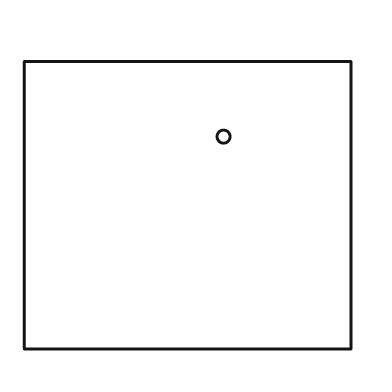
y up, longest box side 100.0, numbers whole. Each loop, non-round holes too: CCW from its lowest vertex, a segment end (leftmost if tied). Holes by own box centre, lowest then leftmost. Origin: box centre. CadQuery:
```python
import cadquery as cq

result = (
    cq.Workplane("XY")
    .moveTo(-50.0, -44.0)
    .lineTo(50.0, -44.0)
    .lineTo(50.0, 44.0)
    .lineTo(-50.0, 44.0)
    .close()
    .moveTo(11.0, 21.0)
    .circle(2.0)
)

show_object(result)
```